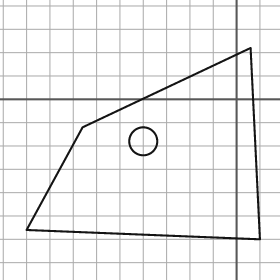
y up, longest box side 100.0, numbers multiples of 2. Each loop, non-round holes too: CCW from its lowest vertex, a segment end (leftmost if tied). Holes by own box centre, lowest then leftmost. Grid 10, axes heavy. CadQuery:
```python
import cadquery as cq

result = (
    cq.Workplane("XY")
    .moveTo(10.0, -60.0)
    .lineTo(6.0, 22.0)
    .lineTo(-66.0, -12.0)
    .lineTo(-90.0, -56.0)
    .close()
    .moveTo(-40.0, -18.0)
    .circle(6.0)
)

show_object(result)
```